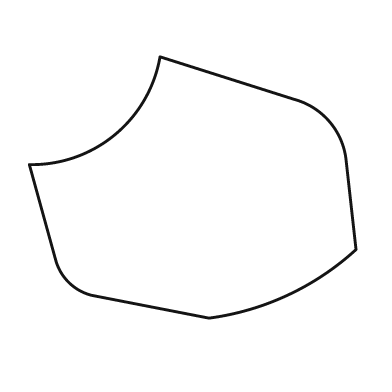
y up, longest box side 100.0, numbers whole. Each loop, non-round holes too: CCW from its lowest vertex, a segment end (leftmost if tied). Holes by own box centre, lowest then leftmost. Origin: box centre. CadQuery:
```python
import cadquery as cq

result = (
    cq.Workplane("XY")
    .moveTo(5.0, -40.0)
    .threePointArc((29.0, -33.0), (50.0, -19.0))
    .lineTo(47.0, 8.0)
    .threePointArc((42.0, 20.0), (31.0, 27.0))
    .lineTo(-10.0, 40.0)
    .threePointArc((-24.0, 16.0), (-50.0, 7.0))
    .lineTo(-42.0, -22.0)
    .threePointArc((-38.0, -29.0), (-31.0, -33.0))
    .close()
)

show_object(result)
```